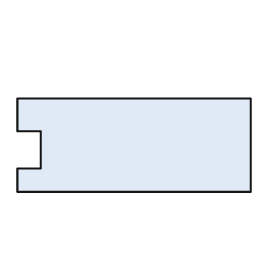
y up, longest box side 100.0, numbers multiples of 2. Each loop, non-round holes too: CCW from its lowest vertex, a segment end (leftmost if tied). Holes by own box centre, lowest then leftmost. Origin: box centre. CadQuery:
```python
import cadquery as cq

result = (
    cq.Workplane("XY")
    .moveTo(-50.0, -20.0)
    .lineTo(50.0, -20.0)
    .lineTo(50.0, 20.0)
    .lineTo(-50.0, 20.0)
    .lineTo(-50.0, 6.0)
    .lineTo(-40.0, 6.0)
    .lineTo(-40.0, -10.0)
    .lineTo(-50.0, -10.0)
    .close()
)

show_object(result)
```